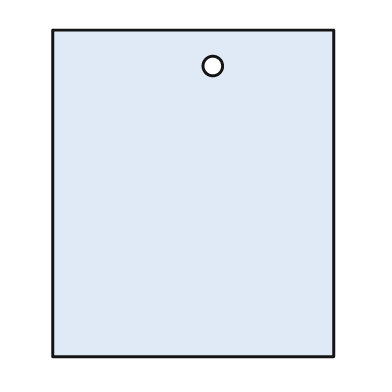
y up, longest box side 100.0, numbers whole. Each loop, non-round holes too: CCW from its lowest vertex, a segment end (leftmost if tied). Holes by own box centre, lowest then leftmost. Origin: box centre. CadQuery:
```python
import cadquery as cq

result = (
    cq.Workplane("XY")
    .moveTo(-43.0, -50.0)
    .lineTo(43.0, -50.0)
    .lineTo(43.0, 50.0)
    .lineTo(-43.0, 50.0)
    .close()
    .moveTo(6.0, 39.0)
    .circle(3.0)
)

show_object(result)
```